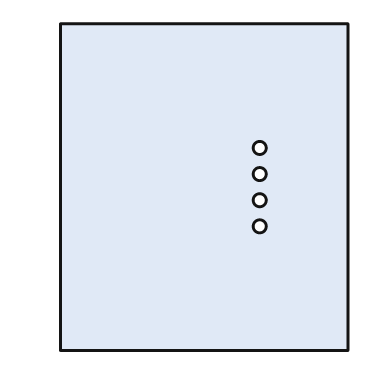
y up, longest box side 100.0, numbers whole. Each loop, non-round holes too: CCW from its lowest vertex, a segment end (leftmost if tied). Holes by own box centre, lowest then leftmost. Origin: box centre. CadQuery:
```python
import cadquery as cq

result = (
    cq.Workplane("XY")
    .moveTo(-44.0, -50.0)
    .lineTo(44.0, -50.0)
    .lineTo(44.0, 50.0)
    .lineTo(-44.0, 50.0)
    .close()
    .moveTo(17.0, -12.0)
    .circle(2.0)
    .moveTo(17.0, -4.0)
    .circle(2.0)
    .moveTo(17.0, 4.0)
    .circle(2.0)
    .moveTo(17.0, 12.0)
    .circle(2.0)
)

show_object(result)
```